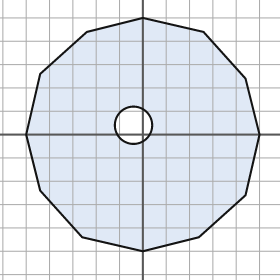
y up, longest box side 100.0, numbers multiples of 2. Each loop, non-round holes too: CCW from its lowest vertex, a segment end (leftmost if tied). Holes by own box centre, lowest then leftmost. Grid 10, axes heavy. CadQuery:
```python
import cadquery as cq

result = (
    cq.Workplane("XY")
    .moveTo(0.0, -50.0)
    .lineTo(24.0, -44.0)
    .lineTo(44.0, -26.0)
    .lineTo(50.0, 0.0)
    .lineTo(44.0, 24.0)
    .lineTo(26.0, 44.0)
    .lineTo(0.0, 50.0)
    .lineTo(-24.0, 44.0)
    .lineTo(-44.0, 26.0)
    .lineTo(-50.0, 0.0)
    .lineTo(-44.0, -24.0)
    .lineTo(-26.0, -44.0)
    .close()
    .moveTo(-4.0, 4.0)
    .circle(8.0)
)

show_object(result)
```